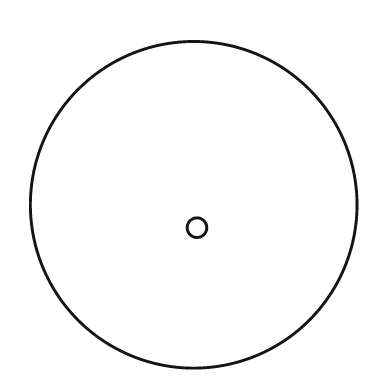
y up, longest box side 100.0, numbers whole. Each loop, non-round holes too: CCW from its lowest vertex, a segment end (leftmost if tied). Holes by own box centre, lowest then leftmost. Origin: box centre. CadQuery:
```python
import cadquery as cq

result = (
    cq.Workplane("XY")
    .moveTo(0.0, 0.0)
    .circle(50.0)
    .moveTo(1.0, -7.0)
    .circle(3.0)
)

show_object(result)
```